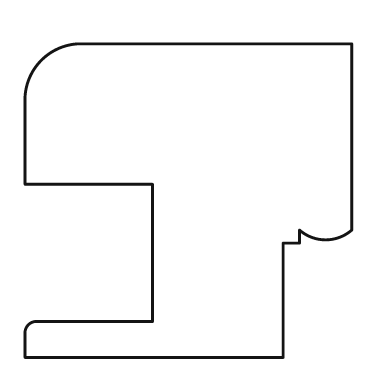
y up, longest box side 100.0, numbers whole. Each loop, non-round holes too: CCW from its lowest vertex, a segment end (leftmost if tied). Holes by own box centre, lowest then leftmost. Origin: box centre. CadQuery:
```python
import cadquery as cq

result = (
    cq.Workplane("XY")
    .moveTo(-50.0, -48.0)
    .lineTo(29.0, -48.0)
    .lineTo(29.0, -13.0)
    .lineTo(34.0, -13.0)
    .lineTo(34.0, -9.0)
    .threePointArc((42.0, -12.0), (50.0, -9.0))
    .lineTo(50.0, 48.0)
    .lineTo(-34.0, 48.0)
    .threePointArc((-45.0, 43.0), (-50.0, 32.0))
    .lineTo(-50.0, 5.0)
    .lineTo(-11.0, 5.0)
    .lineTo(-11.0, -37.0)
    .lineTo(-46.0, -37.0)
    .threePointArc((-49.0, -38.0), (-50.0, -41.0))
    .close()
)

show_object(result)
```